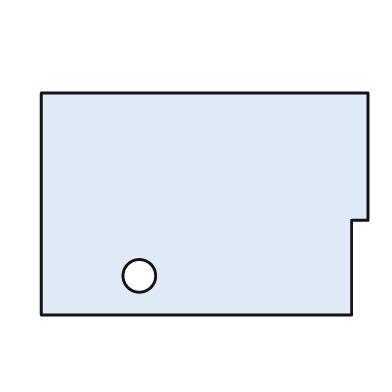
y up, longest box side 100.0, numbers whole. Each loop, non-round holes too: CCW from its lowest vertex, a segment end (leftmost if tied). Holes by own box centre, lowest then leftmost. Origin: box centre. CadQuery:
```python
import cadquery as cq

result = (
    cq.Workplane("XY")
    .moveTo(-50.0, -34.0)
    .lineTo(45.0, -34.0)
    .lineTo(45.0, -5.0)
    .lineTo(50.0, -5.0)
    .lineTo(50.0, 34.0)
    .lineTo(-50.0, 34.0)
    .close()
    .moveTo(-20.0, -22.0)
    .circle(5.0)
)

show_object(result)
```